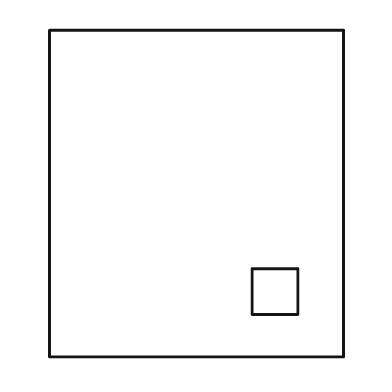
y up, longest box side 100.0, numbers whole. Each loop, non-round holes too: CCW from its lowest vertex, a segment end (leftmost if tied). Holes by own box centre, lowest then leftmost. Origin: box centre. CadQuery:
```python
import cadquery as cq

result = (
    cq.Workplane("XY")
    .moveTo(-45.0, -50.0)
    .lineTo(45.0, -50.0)
    .lineTo(45.0, 50.0)
    .lineTo(-45.0, 50.0)
    .close()
    .moveTo(17.0, -37.0)
    .lineTo(31.0, -37.0)
    .lineTo(31.0, -23.0)
    .lineTo(17.0, -23.0)
    .close()
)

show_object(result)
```